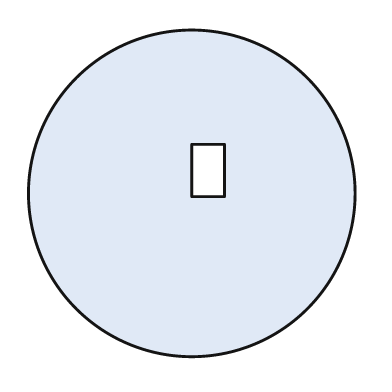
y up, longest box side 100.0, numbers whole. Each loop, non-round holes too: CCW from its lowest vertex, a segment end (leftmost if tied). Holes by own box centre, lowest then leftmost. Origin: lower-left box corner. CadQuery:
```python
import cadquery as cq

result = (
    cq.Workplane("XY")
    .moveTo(50.0, 50.0)
    .circle(50.0)
    .moveTo(50.0, 49.0)
    .lineTo(60.0, 49.0)
    .lineTo(60.0, 65.0)
    .lineTo(50.0, 65.0)
    .close()
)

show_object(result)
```